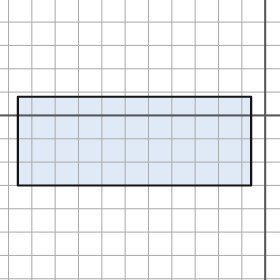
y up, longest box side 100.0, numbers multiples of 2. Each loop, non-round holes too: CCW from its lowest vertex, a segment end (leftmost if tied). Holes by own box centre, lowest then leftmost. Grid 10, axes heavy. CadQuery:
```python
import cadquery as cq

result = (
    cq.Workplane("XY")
    .moveTo(-106.0, -30.0)
    .lineTo(-6.0, -30.0)
    .lineTo(-6.0, 8.0)
    .lineTo(-106.0, 8.0)
    .close()
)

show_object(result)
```